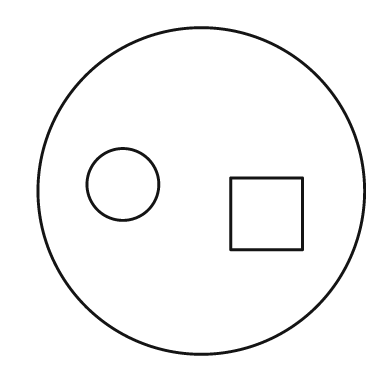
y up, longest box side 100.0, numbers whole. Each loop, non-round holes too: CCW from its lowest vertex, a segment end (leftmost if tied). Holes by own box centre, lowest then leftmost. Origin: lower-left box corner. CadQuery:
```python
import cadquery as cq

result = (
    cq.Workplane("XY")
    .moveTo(50.0, 50.0)
    .circle(50.0)
    .moveTo(59.0, 32.0)
    .lineTo(81.0, 32.0)
    .lineTo(81.0, 54.0)
    .lineTo(59.0, 54.0)
    .close()
    .moveTo(26.0, 52.0)
    .circle(11.0)
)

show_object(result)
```